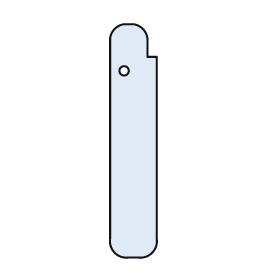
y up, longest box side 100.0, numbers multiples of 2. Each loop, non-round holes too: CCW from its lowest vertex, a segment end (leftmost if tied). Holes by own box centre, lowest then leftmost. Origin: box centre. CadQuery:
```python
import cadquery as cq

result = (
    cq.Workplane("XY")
    .moveTo(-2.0, -50.0)
    .lineTo(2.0, -50.0)
    .threePointArc((8.0, -48.0), (10.0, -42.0))
    .lineTo(10.0, 36.0)
    .lineTo(6.0, 36.0)
    .lineTo(6.0, 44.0)
    .threePointArc((4.0, 48.0), (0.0, 50.0))
    .lineTo(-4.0, 50.0)
    .threePointArc((-8.0, 48.0), (-10.0, 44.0))
    .lineTo(-10.0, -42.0)
    .threePointArc((-8.0, -48.0), (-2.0, -50.0))
    .close()
    .moveTo(-4.0, 30.0)
    .circle(2.0)
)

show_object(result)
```